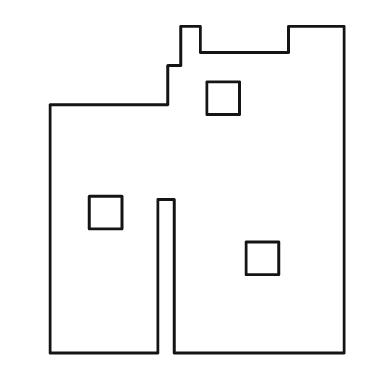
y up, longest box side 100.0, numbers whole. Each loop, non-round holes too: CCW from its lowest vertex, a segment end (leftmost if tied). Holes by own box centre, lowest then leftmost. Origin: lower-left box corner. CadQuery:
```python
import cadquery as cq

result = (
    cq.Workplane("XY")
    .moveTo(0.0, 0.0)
    .lineTo(33.0, 0.0)
    .lineTo(33.0, 47.0)
    .lineTo(38.0, 47.0)
    .lineTo(38.0, 0.0)
    .lineTo(90.0, 0.0)
    .lineTo(90.0, 100.0)
    .lineTo(73.0, 100.0)
    .lineTo(73.0, 92.0)
    .lineTo(46.0, 92.0)
    .lineTo(46.0, 100.0)
    .lineTo(40.0, 100.0)
    .lineTo(40.0, 88.0)
    .lineTo(36.0, 88.0)
    .lineTo(36.0, 76.0)
    .lineTo(0.0, 76.0)
    .close()
    .moveTo(60.0, 24.0)
    .lineTo(70.0, 24.0)
    .lineTo(70.0, 34.0)
    .lineTo(60.0, 34.0)
    .close()
    .moveTo(12.0, 38.0)
    .lineTo(22.0, 38.0)
    .lineTo(22.0, 48.0)
    .lineTo(12.0, 48.0)
    .close()
    .moveTo(48.0, 73.0)
    .lineTo(58.0, 73.0)
    .lineTo(58.0, 83.0)
    .lineTo(48.0, 83.0)
    .close()
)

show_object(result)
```